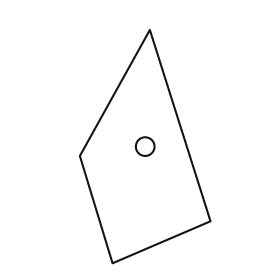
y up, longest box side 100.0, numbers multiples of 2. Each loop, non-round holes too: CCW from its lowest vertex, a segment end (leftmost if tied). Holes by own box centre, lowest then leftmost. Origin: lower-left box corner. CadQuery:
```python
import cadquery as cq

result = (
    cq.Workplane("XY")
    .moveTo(14.0, 0.0)
    .lineTo(56.0, 18.0)
    .lineTo(30.0, 100.0)
    .lineTo(0.0, 46.0)
    .close()
    .moveTo(28.0, 50.0)
    .circle(4.0)
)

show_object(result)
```